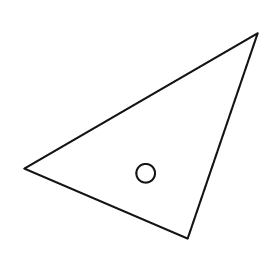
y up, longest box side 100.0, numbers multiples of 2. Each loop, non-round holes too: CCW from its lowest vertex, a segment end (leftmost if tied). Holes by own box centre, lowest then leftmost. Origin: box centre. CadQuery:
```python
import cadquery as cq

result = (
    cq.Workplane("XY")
    .moveTo(20.0, -44.0)
    .lineTo(50.0, 44.0)
    .lineTo(-50.0, -14.0)
    .close()
    .moveTo(2.0, -16.0)
    .circle(4.0)
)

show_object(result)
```